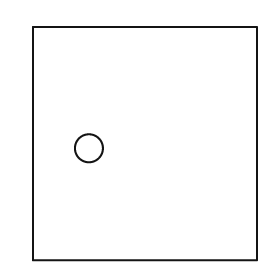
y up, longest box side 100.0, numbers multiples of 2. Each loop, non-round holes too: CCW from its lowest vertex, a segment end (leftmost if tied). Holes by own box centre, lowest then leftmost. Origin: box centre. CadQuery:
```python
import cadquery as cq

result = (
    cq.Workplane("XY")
    .moveTo(-48.0, -50.0)
    .lineTo(48.0, -50.0)
    .lineTo(48.0, 50.0)
    .lineTo(-48.0, 50.0)
    .close()
    .moveTo(-24.0, -2.0)
    .circle(6.0)
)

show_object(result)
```